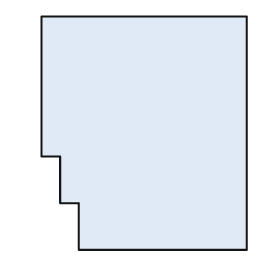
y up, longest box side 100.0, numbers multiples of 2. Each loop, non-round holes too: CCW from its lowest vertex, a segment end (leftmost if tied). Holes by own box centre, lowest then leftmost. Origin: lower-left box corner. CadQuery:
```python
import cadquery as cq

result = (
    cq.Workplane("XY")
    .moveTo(16.0, 0.0)
    .lineTo(88.0, 0.0)
    .lineTo(88.0, 100.0)
    .lineTo(0.0, 100.0)
    .lineTo(0.0, 40.0)
    .lineTo(8.0, 40.0)
    .lineTo(8.0, 20.0)
    .lineTo(16.0, 20.0)
    .close()
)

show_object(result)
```